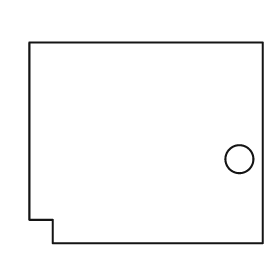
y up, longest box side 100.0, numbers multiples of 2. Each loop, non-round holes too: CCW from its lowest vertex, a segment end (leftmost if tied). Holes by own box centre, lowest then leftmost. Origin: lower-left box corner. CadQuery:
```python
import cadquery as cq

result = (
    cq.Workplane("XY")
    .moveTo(10.0, 0.0)
    .lineTo(100.0, 0.0)
    .lineTo(100.0, 86.0)
    .lineTo(0.0, 86.0)
    .lineTo(0.0, 10.0)
    .lineTo(10.0, 10.0)
    .close()
    .moveTo(90.0, 36.0)
    .circle(6.0)
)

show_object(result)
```